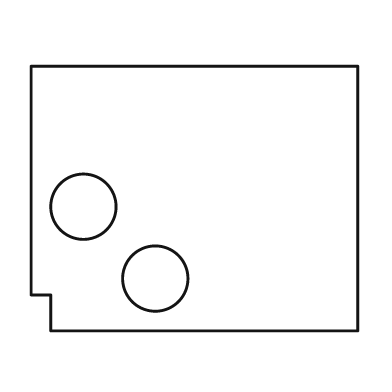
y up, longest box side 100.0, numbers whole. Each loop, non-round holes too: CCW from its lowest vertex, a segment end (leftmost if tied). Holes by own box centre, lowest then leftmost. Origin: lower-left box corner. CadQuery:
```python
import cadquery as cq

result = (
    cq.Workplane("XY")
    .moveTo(6.0, 0.0)
    .lineTo(100.0, 0.0)
    .lineTo(100.0, 81.0)
    .lineTo(0.0, 81.0)
    .lineTo(0.0, 11.0)
    .lineTo(6.0, 11.0)
    .close()
    .moveTo(38.0, 16.0)
    .circle(10.0)
    .moveTo(16.0, 38.0)
    .circle(10.0)
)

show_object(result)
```